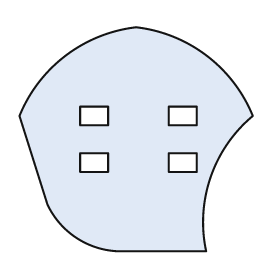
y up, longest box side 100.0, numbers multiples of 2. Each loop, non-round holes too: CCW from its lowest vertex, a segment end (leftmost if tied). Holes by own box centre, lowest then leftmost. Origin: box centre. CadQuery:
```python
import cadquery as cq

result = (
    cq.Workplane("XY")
    .moveTo(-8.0, -48.0)
    .lineTo(30.0, -48.0)
    .threePointArc((32.0, -16.0), (50.0, 10.0))
    .threePointArc((30.0, 36.0), (0.0, 48.0))
    .threePointArc((-30.0, 36.0), (-50.0, 10.0))
    .lineTo(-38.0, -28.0)
    .threePointArc((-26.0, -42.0), (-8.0, -48.0))
    .close()
    .moveTo(-24.0, -14.0)
    .lineTo(-12.0, -14.0)
    .lineTo(-12.0, -6.0)
    .lineTo(-24.0, -6.0)
    .close()
    .moveTo(14.0, -14.0)
    .lineTo(26.0, -14.0)
    .lineTo(26.0, -6.0)
    .lineTo(14.0, -6.0)
    .close()
    .moveTo(-24.0, 6.0)
    .lineTo(-12.0, 6.0)
    .lineTo(-12.0, 14.0)
    .lineTo(-24.0, 14.0)
    .close()
    .moveTo(14.0, 6.0)
    .lineTo(26.0, 6.0)
    .lineTo(26.0, 14.0)
    .lineTo(14.0, 14.0)
    .close()
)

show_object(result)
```